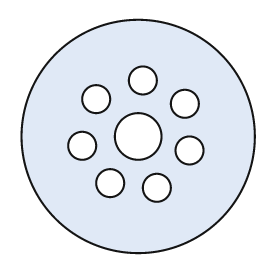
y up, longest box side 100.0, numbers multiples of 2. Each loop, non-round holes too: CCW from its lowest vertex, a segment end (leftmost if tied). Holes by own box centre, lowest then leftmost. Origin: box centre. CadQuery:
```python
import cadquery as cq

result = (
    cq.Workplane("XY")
    .moveTo(0.0, 0.0)
    .circle(50.0)
    .moveTo(8.0, -22.0)
    .circle(6.0)
    .moveTo(-12.0, -20.0)
    .circle(6.0)
    .moveTo(22.0, -6.0)
    .circle(6.0)
    .moveTo(-24.0, -4.0)
    .circle(6.0)
    .moveTo(0.0, 0.0)
    .circle(10.0)
    .moveTo(20.0, 14.0)
    .circle(6.0)
    .moveTo(-18.0, 16.0)
    .circle(6.0)
    .moveTo(2.0, 24.0)
    .circle(6.0)
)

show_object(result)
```